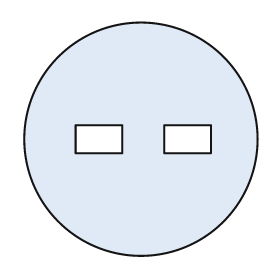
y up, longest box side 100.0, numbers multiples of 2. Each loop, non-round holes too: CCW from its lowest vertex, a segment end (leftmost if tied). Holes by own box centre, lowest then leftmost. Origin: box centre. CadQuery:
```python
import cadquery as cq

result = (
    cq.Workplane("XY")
    .moveTo(0.0, 0.0)
    .circle(50.0)
    .moveTo(-28.0, -6.0)
    .lineTo(-8.0, -6.0)
    .lineTo(-8.0, 6.0)
    .lineTo(-28.0, 6.0)
    .close()
    .moveTo(10.0, -6.0)
    .lineTo(30.0, -6.0)
    .lineTo(30.0, 6.0)
    .lineTo(10.0, 6.0)
    .close()
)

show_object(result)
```